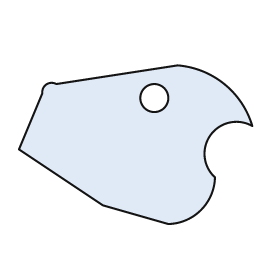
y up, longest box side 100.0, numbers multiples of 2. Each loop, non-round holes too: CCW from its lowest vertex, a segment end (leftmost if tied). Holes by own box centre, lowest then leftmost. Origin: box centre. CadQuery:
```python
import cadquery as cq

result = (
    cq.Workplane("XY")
    .moveTo(14.0, -34.0)
    .threePointArc((28.0, -28.0), (34.0, -14.0))
    .threePointArc((32.0, 4.0), (50.0, 8.0))
    .threePointArc((38.0, 26.0), (18.0, 34.0))
    .lineTo(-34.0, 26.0)
    .threePointArc((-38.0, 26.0), (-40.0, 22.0))
    .lineTo(-50.0, -2.0)
    .lineTo(-14.0, -26.0)
    .close()
    .moveTo(8.0, 20.0)
    .circle(6.0)
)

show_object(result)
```